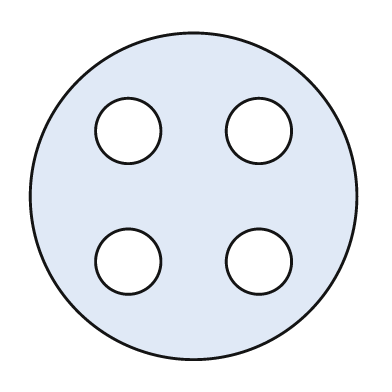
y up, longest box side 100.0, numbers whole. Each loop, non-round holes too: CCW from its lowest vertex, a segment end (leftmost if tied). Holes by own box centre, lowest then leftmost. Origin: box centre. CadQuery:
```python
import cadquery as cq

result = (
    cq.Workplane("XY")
    .moveTo(0.0, 0.0)
    .circle(50.0)
    .moveTo(-20.0, -20.0)
    .circle(10.0)
    .moveTo(20.0, -20.0)
    .circle(10.0)
    .moveTo(-20.0, 20.0)
    .circle(10.0)
    .moveTo(20.0, 20.0)
    .circle(10.0)
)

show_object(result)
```